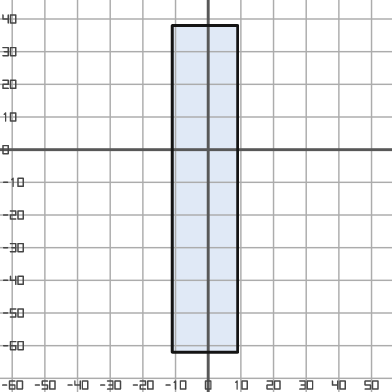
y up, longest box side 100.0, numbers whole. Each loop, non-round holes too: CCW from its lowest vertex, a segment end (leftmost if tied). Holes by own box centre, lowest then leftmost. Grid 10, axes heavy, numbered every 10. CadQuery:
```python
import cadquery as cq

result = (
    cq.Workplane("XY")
    .moveTo(-11.0, -62.0)
    .lineTo(9.0, -62.0)
    .lineTo(9.0, 38.0)
    .lineTo(-11.0, 38.0)
    .close()
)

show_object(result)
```